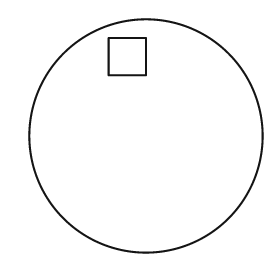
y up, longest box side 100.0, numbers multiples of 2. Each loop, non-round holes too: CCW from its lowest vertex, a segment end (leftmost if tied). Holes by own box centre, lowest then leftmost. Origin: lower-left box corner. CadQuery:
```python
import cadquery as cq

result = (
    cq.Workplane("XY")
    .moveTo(50.0, 50.0)
    .circle(50.0)
    .moveTo(34.0, 76.0)
    .lineTo(50.0, 76.0)
    .lineTo(50.0, 92.0)
    .lineTo(34.0, 92.0)
    .close()
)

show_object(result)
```